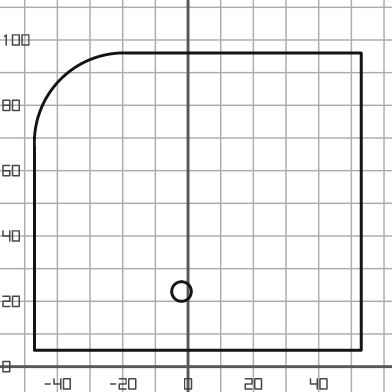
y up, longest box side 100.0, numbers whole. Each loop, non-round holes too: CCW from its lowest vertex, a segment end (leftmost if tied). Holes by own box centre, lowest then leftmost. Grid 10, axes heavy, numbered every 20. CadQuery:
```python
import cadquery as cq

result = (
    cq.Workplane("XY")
    .moveTo(-47.0, 5.0)
    .lineTo(53.0, 5.0)
    .lineTo(53.0, 96.0)
    .lineTo(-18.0, 96.0)
    .threePointArc((-39.0, 88.0), (-47.0, 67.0))
    .close()
    .moveTo(-2.0, 23.0)
    .circle(3.0)
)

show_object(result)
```